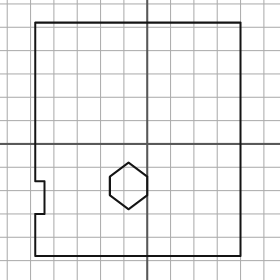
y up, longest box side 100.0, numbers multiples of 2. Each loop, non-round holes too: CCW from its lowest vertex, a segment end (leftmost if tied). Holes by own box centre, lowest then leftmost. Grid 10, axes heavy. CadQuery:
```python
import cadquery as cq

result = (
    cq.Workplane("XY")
    .moveTo(-48.0, -48.0)
    .lineTo(40.0, -48.0)
    .lineTo(40.0, 52.0)
    .lineTo(-48.0, 52.0)
    .lineTo(-48.0, -16.0)
    .lineTo(-44.0, -16.0)
    .lineTo(-44.0, -30.0)
    .lineTo(-48.0, -30.0)
    .close()
    .moveTo(-8.0, -28.0)
    .lineTo(0.0, -22.0)
    .lineTo(0.0, -14.0)
    .lineTo(-8.0, -8.0)
    .lineTo(-16.0, -14.0)
    .lineTo(-16.0, -22.0)
    .close()
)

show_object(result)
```